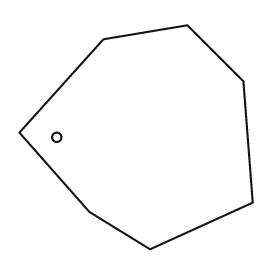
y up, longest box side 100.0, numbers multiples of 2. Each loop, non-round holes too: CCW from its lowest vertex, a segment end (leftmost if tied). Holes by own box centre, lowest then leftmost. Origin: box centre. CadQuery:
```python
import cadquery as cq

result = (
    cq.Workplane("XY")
    .moveTo(6.0, -48.0)
    .lineTo(50.0, -28.0)
    .lineTo(46.0, 24.0)
    .lineTo(22.0, 48.0)
    .lineTo(-14.0, 42.0)
    .lineTo(-50.0, 2.0)
    .lineTo(-20.0, -32.0)
    .close()
    .moveTo(-34.0, 0.0)
    .circle(2.0)
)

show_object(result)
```